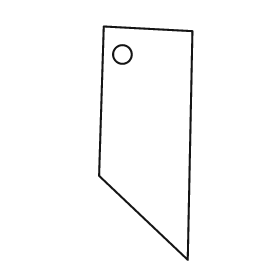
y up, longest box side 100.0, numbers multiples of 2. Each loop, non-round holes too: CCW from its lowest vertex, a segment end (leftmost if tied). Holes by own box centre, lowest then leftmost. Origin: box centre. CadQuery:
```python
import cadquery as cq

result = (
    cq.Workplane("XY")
    .moveTo(18.0, -50.0)
    .lineTo(20.0, 48.0)
    .lineTo(-18.0, 50.0)
    .lineTo(-20.0, -14.0)
    .close()
    .moveTo(-10.0, 38.0)
    .circle(4.0)
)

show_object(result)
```